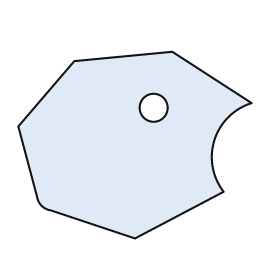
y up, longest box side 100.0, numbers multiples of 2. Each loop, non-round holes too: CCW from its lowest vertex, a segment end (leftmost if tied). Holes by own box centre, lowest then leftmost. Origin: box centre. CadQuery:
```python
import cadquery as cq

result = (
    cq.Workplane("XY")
    .moveTo(0.0, -40.0)
    .lineTo(38.0, -20.0)
    .threePointArc((34.0, 2.0), (50.0, 18.0))
    .lineTo(16.0, 40.0)
    .lineTo(-26.0, 36.0)
    .lineTo(-50.0, 8.0)
    .lineTo(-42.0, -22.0)
    .threePointArc((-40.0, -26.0), (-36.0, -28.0))
    .close()
    .moveTo(8.0, 16.0)
    .circle(6.0)
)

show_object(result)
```